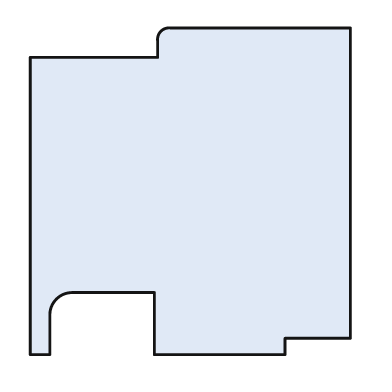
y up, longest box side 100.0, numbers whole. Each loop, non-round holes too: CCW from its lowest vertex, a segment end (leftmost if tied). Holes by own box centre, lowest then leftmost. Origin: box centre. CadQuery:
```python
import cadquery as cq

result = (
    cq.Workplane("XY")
    .moveTo(-49.0, -50.0)
    .lineTo(-43.0, -50.0)
    .lineTo(-43.0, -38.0)
    .threePointArc((-41.0, -33.0), (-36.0, -31.0))
    .lineTo(-11.0, -31.0)
    .lineTo(-11.0, -50.0)
    .lineTo(29.0, -50.0)
    .lineTo(29.0, -45.0)
    .lineTo(49.0, -45.0)
    .lineTo(49.0, 50.0)
    .lineTo(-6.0, 50.0)
    .threePointArc((-9.0, 49.0), (-10.0, 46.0))
    .lineTo(-10.0, 41.0)
    .lineTo(-49.0, 41.0)
    .close()
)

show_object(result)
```